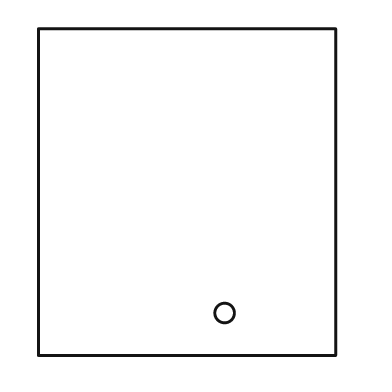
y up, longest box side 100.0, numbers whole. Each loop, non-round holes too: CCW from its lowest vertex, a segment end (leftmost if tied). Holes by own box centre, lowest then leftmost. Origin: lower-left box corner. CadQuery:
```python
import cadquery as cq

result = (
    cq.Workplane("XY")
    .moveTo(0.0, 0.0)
    .lineTo(91.0, 0.0)
    .lineTo(91.0, 100.0)
    .lineTo(0.0, 100.0)
    .close()
    .moveTo(57.0, 13.0)
    .circle(3.0)
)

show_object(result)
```